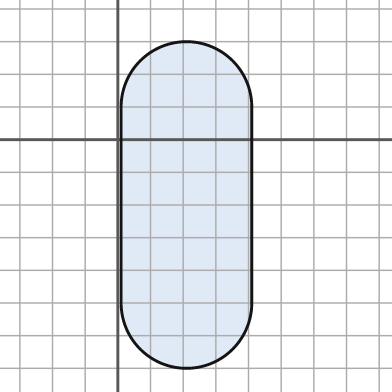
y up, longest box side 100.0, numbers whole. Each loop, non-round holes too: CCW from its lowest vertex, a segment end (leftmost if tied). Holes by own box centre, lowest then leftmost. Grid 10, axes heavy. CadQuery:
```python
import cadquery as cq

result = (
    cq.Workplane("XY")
    .moveTo(1.0, -50.0)
    .threePointArc((21.0, -70.0), (41.0, -50.0))
    .lineTo(41.0, 10.0)
    .threePointArc((21.0, 30.0), (1.0, 10.0))
    .close()
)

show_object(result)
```